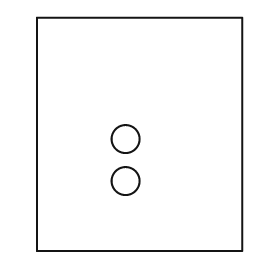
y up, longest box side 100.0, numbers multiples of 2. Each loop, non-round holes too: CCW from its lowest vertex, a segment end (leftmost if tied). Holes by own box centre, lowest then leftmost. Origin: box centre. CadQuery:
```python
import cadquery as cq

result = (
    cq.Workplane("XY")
    .moveTo(-44.0, -50.0)
    .lineTo(44.0, -50.0)
    .lineTo(44.0, 50.0)
    .lineTo(-44.0, 50.0)
    .close()
    .moveTo(-6.0, -20.0)
    .circle(6.0)
    .moveTo(-6.0, -2.0)
    .circle(6.0)
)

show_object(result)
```